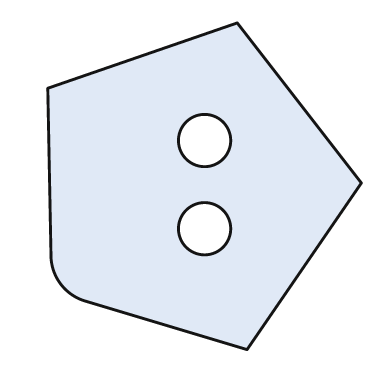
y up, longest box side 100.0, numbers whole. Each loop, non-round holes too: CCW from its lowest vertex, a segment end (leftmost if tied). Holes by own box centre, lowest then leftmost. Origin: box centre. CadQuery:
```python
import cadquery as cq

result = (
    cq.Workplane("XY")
    .moveTo(13.0, -50.0)
    .lineTo(48.0, 1.0)
    .lineTo(10.0, 50.0)
    .lineTo(-48.0, 30.0)
    .lineTo(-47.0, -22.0)
    .threePointArc((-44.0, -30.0), (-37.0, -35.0))
    .close()
    .moveTo(0.0, -13.0)
    .circle(8.0)
    .moveTo(0.0, 14.0)
    .circle(8.0)
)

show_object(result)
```